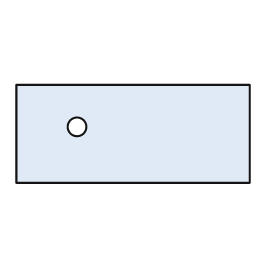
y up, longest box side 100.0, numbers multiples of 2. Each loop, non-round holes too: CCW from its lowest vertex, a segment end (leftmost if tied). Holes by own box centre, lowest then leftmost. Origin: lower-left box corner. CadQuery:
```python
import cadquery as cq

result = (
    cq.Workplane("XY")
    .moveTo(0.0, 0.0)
    .lineTo(100.0, 0.0)
    .lineTo(100.0, 42.0)
    .lineTo(0.0, 42.0)
    .close()
    .moveTo(26.0, 24.0)
    .circle(4.0)
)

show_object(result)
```